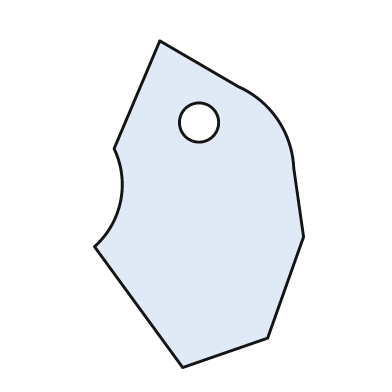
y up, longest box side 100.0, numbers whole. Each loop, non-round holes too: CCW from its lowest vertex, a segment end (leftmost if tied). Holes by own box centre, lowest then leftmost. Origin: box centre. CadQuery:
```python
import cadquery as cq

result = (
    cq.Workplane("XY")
    .moveTo(-5.0, -50.0)
    .lineTo(21.0, -41.0)
    .lineTo(32.0, -10.0)
    .lineTo(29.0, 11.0)
    .threePointArc((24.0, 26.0), (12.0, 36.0))
    .lineTo(-12.0, 50.0)
    .lineTo(-26.0, 17.0)
    .threePointArc((-24.0, 1.0), (-32.0, -13.0))
    .close()
    .moveTo(0.0, 25.0)
    .circle(6.0)
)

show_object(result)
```